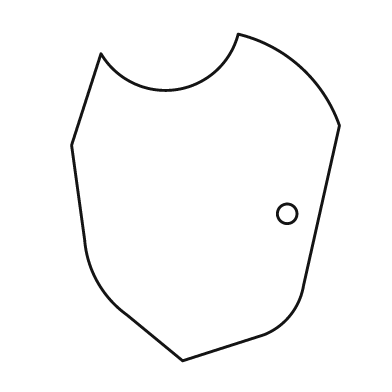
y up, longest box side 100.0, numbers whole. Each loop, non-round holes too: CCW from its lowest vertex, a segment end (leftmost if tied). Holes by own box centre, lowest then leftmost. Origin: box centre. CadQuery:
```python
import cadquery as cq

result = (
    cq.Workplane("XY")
    .moveTo(-7.0, -50.0)
    .lineTo(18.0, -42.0)
    .threePointArc((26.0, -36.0), (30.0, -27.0))
    .lineTo(41.0, 22.0)
    .threePointArc((29.0, 40.0), (10.0, 50.0))
    .threePointArc((-9.0, 33.0), (-32.0, 44.0))
    .lineTo(-41.0, 16.0)
    .lineTo(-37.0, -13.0)
    .threePointArc((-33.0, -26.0), (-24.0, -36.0))
    .close()
    .moveTo(25.0, -5.0)
    .circle(3.0)
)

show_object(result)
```